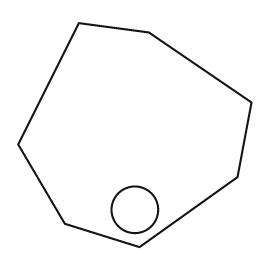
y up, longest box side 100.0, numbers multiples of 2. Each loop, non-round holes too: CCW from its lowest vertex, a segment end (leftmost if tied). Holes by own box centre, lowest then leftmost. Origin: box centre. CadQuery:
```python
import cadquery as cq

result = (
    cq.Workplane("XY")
    .moveTo(2.0, -48.0)
    .lineTo(44.0, -18.0)
    .lineTo(50.0, 14.0)
    .lineTo(6.0, 44.0)
    .lineTo(-24.0, 48.0)
    .lineTo(-50.0, -4.0)
    .lineTo(-30.0, -38.0)
    .close()
    .moveTo(0.0, -32.0)
    .circle(10.0)
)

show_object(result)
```